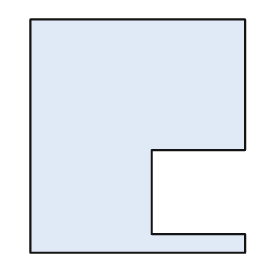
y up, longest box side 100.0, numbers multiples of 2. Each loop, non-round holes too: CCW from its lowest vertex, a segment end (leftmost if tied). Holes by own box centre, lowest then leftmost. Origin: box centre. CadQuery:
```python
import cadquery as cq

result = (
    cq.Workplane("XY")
    .moveTo(-46.0, -50.0)
    .lineTo(46.0, -50.0)
    .lineTo(46.0, -42.0)
    .lineTo(6.0, -42.0)
    .lineTo(6.0, -6.0)
    .lineTo(46.0, -6.0)
    .lineTo(46.0, 50.0)
    .lineTo(-46.0, 50.0)
    .close()
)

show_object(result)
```